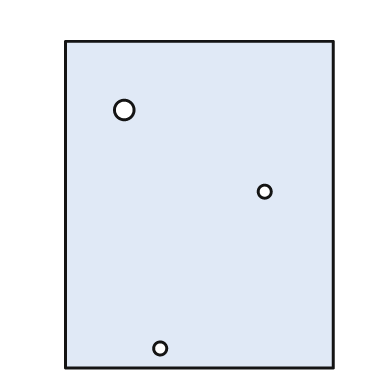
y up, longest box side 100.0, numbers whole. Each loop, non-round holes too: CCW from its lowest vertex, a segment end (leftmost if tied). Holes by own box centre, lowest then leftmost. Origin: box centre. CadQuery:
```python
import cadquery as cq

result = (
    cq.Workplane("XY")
    .moveTo(-41.0, -50.0)
    .lineTo(41.0, -50.0)
    .lineTo(41.0, 50.0)
    .lineTo(-41.0, 50.0)
    .close()
    .moveTo(-12.0, -44.0)
    .circle(2.0)
    .moveTo(20.0, 4.0)
    .circle(2.0)
    .moveTo(-23.0, 29.0)
    .circle(3.0)
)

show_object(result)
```